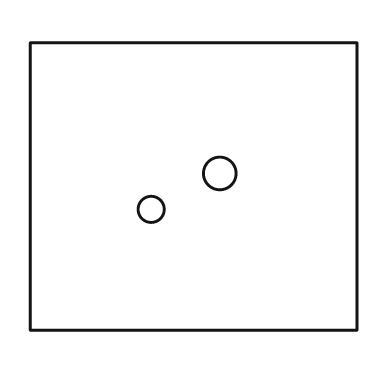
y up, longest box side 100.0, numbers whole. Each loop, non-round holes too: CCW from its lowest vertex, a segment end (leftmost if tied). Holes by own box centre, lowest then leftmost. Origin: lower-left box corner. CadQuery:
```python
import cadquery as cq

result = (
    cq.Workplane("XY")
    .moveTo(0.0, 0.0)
    .lineTo(100.0, 0.0)
    .lineTo(100.0, 88.0)
    .lineTo(0.0, 88.0)
    .close()
    .moveTo(37.0, 37.0)
    .circle(4.0)
    .moveTo(58.0, 48.0)
    .circle(5.0)
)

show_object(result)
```